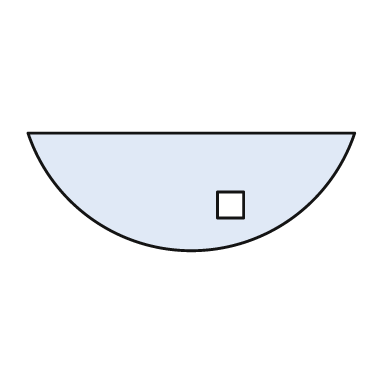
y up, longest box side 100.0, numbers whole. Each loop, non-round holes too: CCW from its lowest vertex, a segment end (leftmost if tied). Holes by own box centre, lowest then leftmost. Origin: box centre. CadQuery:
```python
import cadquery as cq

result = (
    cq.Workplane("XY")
    .moveTo(-50.0, 18.0)
    .threePointArc((0.0, -18.0), (50.0, 18.0))
    .close()
    .moveTo(8.0, -8.0)
    .lineTo(16.0, -8.0)
    .lineTo(16.0, 0.0)
    .lineTo(8.0, 0.0)
    .close()
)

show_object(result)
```